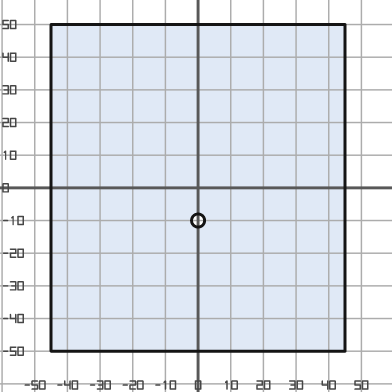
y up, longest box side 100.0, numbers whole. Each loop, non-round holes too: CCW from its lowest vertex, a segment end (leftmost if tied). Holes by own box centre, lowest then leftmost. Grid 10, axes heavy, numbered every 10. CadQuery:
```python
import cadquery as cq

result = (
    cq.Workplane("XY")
    .moveTo(-45.0, -50.0)
    .lineTo(45.0, -50.0)
    .lineTo(45.0, 50.0)
    .lineTo(-45.0, 50.0)
    .close()
    .moveTo(0.0, -10.0)
    .circle(2.0)
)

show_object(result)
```